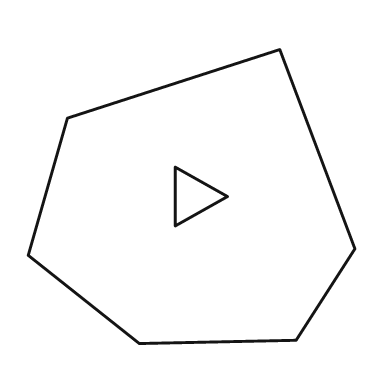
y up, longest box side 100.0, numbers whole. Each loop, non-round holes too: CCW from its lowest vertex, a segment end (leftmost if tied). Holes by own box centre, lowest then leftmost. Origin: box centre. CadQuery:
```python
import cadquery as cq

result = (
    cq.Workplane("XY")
    .moveTo(-16.0, -45.0)
    .lineTo(32.0, -44.0)
    .lineTo(50.0, -16.0)
    .lineTo(27.0, 45.0)
    .lineTo(-38.0, 24.0)
    .lineTo(-50.0, -18.0)
    .close()
    .moveTo(-5.0, -9.0)
    .lineTo(11.0, 0.0)
    .lineTo(-5.0, 9.0)
    .close()
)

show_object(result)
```